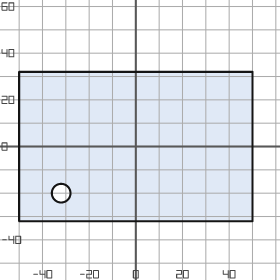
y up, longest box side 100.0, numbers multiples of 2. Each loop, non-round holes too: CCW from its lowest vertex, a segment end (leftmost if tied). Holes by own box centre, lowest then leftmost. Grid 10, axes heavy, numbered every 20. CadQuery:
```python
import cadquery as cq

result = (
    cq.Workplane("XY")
    .moveTo(-50.0, -32.0)
    .lineTo(50.0, -32.0)
    .lineTo(50.0, 32.0)
    .lineTo(-50.0, 32.0)
    .close()
    .moveTo(-32.0, -20.0)
    .circle(4.0)
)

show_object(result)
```